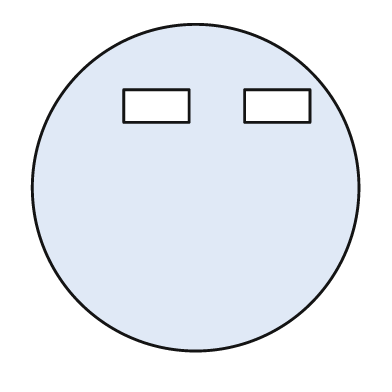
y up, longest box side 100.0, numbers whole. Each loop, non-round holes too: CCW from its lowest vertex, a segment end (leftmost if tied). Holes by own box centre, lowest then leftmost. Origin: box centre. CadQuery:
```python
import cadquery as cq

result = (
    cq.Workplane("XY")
    .moveTo(0.0, 0.0)
    .circle(50.0)
    .moveTo(-22.0, 20.0)
    .lineTo(-2.0, 20.0)
    .lineTo(-2.0, 30.0)
    .lineTo(-22.0, 30.0)
    .close()
    .moveTo(15.0, 20.0)
    .lineTo(35.0, 20.0)
    .lineTo(35.0, 30.0)
    .lineTo(15.0, 30.0)
    .close()
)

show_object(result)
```